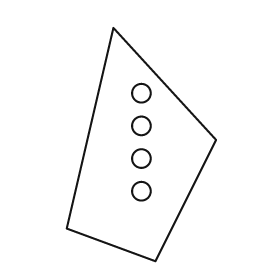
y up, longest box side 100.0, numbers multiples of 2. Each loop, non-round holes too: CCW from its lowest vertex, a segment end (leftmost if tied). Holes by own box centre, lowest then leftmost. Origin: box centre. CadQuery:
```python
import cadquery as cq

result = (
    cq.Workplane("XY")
    .moveTo(6.0, -50.0)
    .lineTo(32.0, 2.0)
    .lineTo(-12.0, 50.0)
    .lineTo(-32.0, -36.0)
    .close()
    .moveTo(0.0, -20.0)
    .circle(4.0)
    .moveTo(0.0, -6.0)
    .circle(4.0)
    .moveTo(0.0, 8.0)
    .circle(4.0)
    .moveTo(0.0, 22.0)
    .circle(4.0)
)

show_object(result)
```